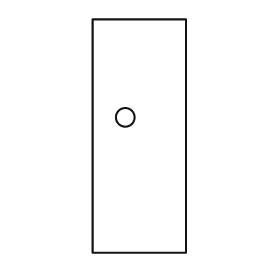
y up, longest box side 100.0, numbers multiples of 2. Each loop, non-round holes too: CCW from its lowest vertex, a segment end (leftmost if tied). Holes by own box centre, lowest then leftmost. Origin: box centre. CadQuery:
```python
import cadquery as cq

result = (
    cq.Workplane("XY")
    .moveTo(-20.0, -50.0)
    .lineTo(20.0, -50.0)
    .lineTo(20.0, 50.0)
    .lineTo(-20.0, 50.0)
    .close()
    .moveTo(-6.0, 8.0)
    .circle(4.0)
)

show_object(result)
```